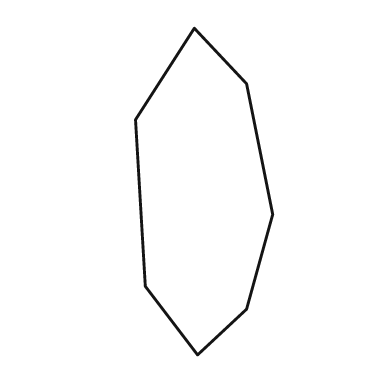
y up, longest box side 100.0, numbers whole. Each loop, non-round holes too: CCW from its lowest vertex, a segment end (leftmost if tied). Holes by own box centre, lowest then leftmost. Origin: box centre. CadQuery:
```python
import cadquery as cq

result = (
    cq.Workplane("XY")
    .moveTo(-2.0, -50.0)
    .lineTo(13.0, -36.0)
    .lineTo(21.0, -7.0)
    .lineTo(13.0, 33.0)
    .lineTo(-3.0, 50.0)
    .lineTo(-21.0, 22.0)
    .lineTo(-18.0, -29.0)
    .close()
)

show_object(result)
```